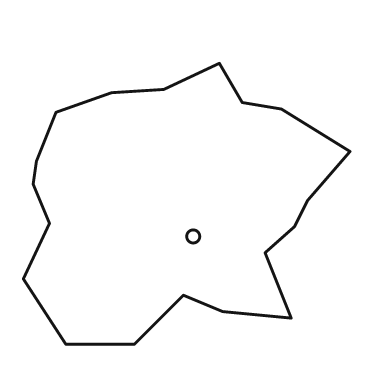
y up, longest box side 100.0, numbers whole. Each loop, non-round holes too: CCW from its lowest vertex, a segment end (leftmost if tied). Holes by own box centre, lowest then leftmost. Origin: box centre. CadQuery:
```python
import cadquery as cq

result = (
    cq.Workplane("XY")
    .moveTo(-37.0, -43.0)
    .lineTo(-16.0, -43.0)
    .lineTo(-1.0, -28.0)
    .lineTo(11.0, -33.0)
    .lineTo(32.0, -35.0)
    .lineTo(24.0, -15.0)
    .lineTo(33.0, -7.0)
    .lineTo(37.0, 1.0)
    .lineTo(50.0, 16.0)
    .lineTo(29.0, 29.0)
    .lineTo(17.0, 31.0)
    .lineTo(10.0, 43.0)
    .lineTo(-7.0, 35.0)
    .lineTo(-23.0, 34.0)
    .lineTo(-40.0, 28.0)
    .lineTo(-46.0, 13.0)
    .lineTo(-47.0, 6.0)
    .lineTo(-42.0, -6.0)
    .lineTo(-50.0, -23.0)
    .close()
    .moveTo(2.0, -10.0)
    .circle(2.0)
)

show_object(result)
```